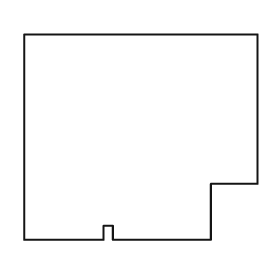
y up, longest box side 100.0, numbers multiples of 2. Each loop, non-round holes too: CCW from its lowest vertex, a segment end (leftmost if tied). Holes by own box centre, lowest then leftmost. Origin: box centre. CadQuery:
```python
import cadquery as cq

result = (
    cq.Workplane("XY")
    .moveTo(-50.0, -44.0)
    .lineTo(-16.0, -44.0)
    .lineTo(-16.0, -38.0)
    .lineTo(-12.0, -38.0)
    .lineTo(-12.0, -44.0)
    .lineTo(30.0, -44.0)
    .lineTo(30.0, -20.0)
    .lineTo(50.0, -20.0)
    .lineTo(50.0, 44.0)
    .lineTo(-50.0, 44.0)
    .close()
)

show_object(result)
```